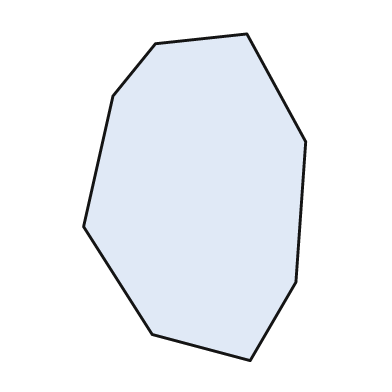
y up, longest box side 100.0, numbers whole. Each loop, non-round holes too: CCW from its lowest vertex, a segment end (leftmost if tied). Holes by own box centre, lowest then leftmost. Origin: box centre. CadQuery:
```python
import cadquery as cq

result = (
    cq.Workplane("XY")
    .moveTo(17.0, -50.0)
    .lineTo(31.0, -26.0)
    .lineTo(34.0, 17.0)
    .lineTo(16.0, 50.0)
    .lineTo(-12.0, 47.0)
    .lineTo(-25.0, 31.0)
    .lineTo(-34.0, -9.0)
    .lineTo(-13.0, -42.0)
    .close()
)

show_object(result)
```